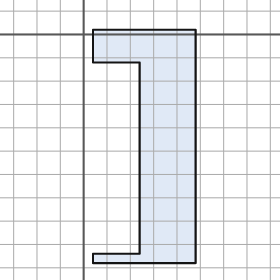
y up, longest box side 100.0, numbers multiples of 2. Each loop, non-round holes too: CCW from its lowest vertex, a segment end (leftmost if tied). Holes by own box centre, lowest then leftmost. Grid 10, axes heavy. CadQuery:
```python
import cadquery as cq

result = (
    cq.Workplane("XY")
    .moveTo(4.0, -98.0)
    .lineTo(48.0, -98.0)
    .lineTo(48.0, 2.0)
    .lineTo(4.0, 2.0)
    .lineTo(4.0, -12.0)
    .lineTo(24.0, -12.0)
    .lineTo(24.0, -94.0)
    .lineTo(4.0, -94.0)
    .close()
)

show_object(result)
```